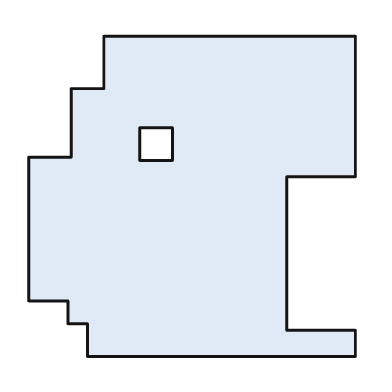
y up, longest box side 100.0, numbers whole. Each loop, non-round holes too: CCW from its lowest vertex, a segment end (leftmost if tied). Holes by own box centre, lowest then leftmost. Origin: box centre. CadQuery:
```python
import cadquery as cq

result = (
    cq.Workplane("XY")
    .moveTo(-32.0, -49.0)
    .lineTo(50.0, -49.0)
    .lineTo(50.0, -41.0)
    .lineTo(29.0, -41.0)
    .lineTo(29.0, 6.0)
    .lineTo(50.0, 6.0)
    .lineTo(50.0, 49.0)
    .lineTo(-27.0, 49.0)
    .lineTo(-27.0, 33.0)
    .lineTo(-37.0, 33.0)
    .lineTo(-37.0, 12.0)
    .lineTo(-50.0, 12.0)
    .lineTo(-50.0, -32.0)
    .lineTo(-38.0, -32.0)
    .lineTo(-38.0, -39.0)
    .lineTo(-32.0, -39.0)
    .close()
    .moveTo(-16.0, 11.0)
    .lineTo(-6.0, 11.0)
    .lineTo(-6.0, 21.0)
    .lineTo(-16.0, 21.0)
    .close()
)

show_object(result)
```